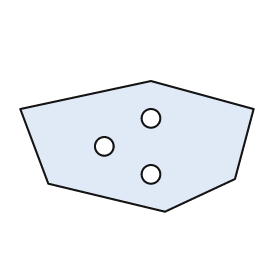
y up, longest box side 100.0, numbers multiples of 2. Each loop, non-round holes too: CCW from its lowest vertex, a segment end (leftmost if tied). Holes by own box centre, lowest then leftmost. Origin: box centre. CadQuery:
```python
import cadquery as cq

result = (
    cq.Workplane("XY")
    .moveTo(12.0, -28.0)
    .lineTo(42.0, -14.0)
    .lineTo(50.0, 16.0)
    .lineTo(6.0, 28.0)
    .lineTo(-50.0, 16.0)
    .lineTo(-38.0, -16.0)
    .close()
    .moveTo(6.0, -12.0)
    .circle(4.0)
    .moveTo(-14.0, 0.0)
    .circle(4.0)
    .moveTo(6.0, 12.0)
    .circle(4.0)
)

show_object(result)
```